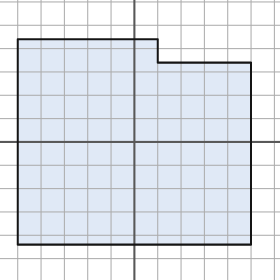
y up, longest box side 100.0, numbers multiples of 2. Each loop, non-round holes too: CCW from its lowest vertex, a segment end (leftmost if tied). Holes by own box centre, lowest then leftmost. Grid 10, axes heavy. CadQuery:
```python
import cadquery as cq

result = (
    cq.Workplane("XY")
    .moveTo(-50.0, -44.0)
    .lineTo(50.0, -44.0)
    .lineTo(50.0, 34.0)
    .lineTo(10.0, 34.0)
    .lineTo(10.0, 44.0)
    .lineTo(-50.0, 44.0)
    .close()
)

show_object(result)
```